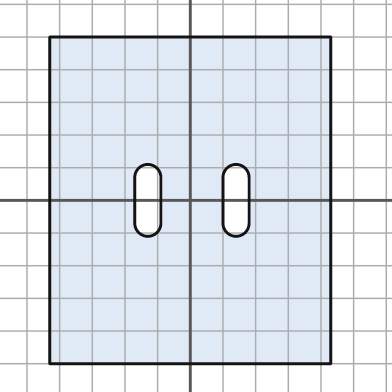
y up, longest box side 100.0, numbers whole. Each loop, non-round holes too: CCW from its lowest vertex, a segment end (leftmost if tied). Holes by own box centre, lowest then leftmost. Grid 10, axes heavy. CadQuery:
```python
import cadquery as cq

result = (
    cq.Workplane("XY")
    .moveTo(-43.0, -50.0)
    .lineTo(43.0, -50.0)
    .lineTo(43.0, 50.0)
    .lineTo(-43.0, 50.0)
    .close()
    .moveTo(-17.0, -7.0)
    .threePointArc((-13.0, -11.0), (-9.0, -7.0))
    .lineTo(-9.0, 7.0)
    .threePointArc((-13.0, 11.0), (-17.0, 7.0))
    .close()
    .moveTo(10.0, -7.0)
    .threePointArc((14.0, -11.0), (18.0, -7.0))
    .lineTo(18.0, 7.0)
    .threePointArc((14.0, 11.0), (10.0, 7.0))
    .close()
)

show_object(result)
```